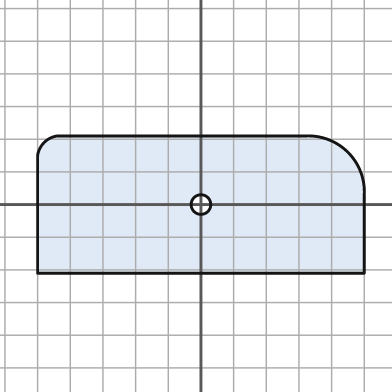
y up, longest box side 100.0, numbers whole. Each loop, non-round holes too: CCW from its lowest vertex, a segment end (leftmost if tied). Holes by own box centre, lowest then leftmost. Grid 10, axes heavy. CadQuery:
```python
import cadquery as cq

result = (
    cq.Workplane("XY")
    .moveTo(-50.0, -21.0)
    .lineTo(50.0, -21.0)
    .lineTo(50.0, 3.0)
    .threePointArc((45.0, 16.0), (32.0, 21.0))
    .lineTo(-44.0, 21.0)
    .threePointArc((-48.0, 19.0), (-50.0, 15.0))
    .close()
    .moveTo(0.0, 0.0)
    .circle(3.0)
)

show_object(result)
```